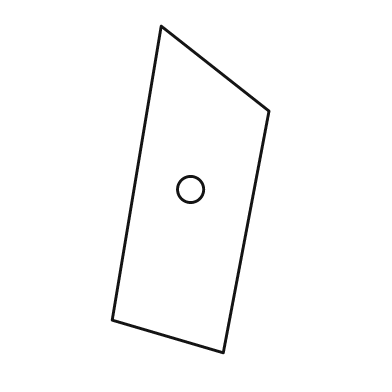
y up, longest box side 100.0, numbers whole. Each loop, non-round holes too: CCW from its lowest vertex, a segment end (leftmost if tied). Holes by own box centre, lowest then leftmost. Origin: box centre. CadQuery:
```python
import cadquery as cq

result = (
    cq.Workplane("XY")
    .moveTo(10.0, -50.0)
    .lineTo(24.0, 24.0)
    .lineTo(-9.0, 50.0)
    .lineTo(-24.0, -40.0)
    .close()
    .moveTo(0.0, 0.0)
    .circle(4.0)
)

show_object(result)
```